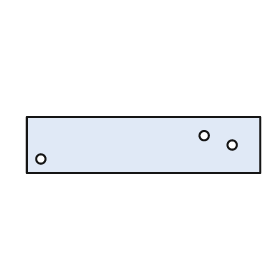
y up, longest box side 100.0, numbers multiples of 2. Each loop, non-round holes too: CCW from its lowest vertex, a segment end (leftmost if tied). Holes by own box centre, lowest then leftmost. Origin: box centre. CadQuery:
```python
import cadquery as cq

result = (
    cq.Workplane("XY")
    .moveTo(-50.0, -12.0)
    .lineTo(50.0, -12.0)
    .lineTo(50.0, 12.0)
    .lineTo(-50.0, 12.0)
    .close()
    .moveTo(-44.0, -6.0)
    .circle(2.0)
    .moveTo(38.0, 0.0)
    .circle(2.0)
    .moveTo(26.0, 4.0)
    .circle(2.0)
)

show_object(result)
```